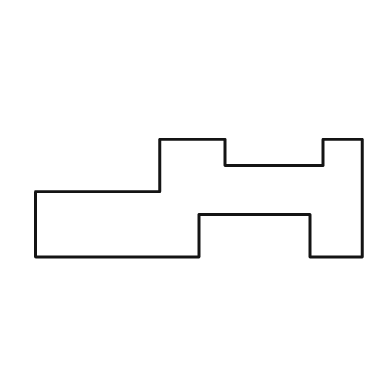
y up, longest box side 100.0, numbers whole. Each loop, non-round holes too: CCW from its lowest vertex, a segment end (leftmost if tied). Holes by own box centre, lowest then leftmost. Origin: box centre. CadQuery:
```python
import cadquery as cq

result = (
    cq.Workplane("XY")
    .moveTo(-50.0, -18.0)
    .lineTo(0.0, -18.0)
    .lineTo(0.0, -5.0)
    .lineTo(34.0, -5.0)
    .lineTo(34.0, -18.0)
    .lineTo(50.0, -18.0)
    .lineTo(50.0, 18.0)
    .lineTo(38.0, 18.0)
    .lineTo(38.0, 10.0)
    .lineTo(8.0, 10.0)
    .lineTo(8.0, 18.0)
    .lineTo(-12.0, 18.0)
    .lineTo(-12.0, 2.0)
    .lineTo(-50.0, 2.0)
    .close()
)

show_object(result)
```